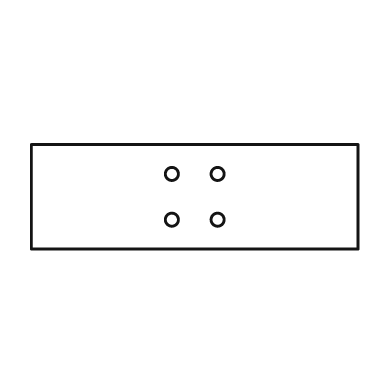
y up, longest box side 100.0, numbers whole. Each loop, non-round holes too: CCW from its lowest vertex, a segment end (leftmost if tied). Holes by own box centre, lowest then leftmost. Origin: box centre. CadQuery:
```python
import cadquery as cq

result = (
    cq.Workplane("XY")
    .moveTo(-50.0, -16.0)
    .lineTo(50.0, -16.0)
    .lineTo(50.0, 16.0)
    .lineTo(-50.0, 16.0)
    .close()
    .moveTo(-7.0, -7.0)
    .circle(2.0)
    .moveTo(7.0, -7.0)
    .circle(2.0)
    .moveTo(-7.0, 7.0)
    .circle(2.0)
    .moveTo(7.0, 7.0)
    .circle(2.0)
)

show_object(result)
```